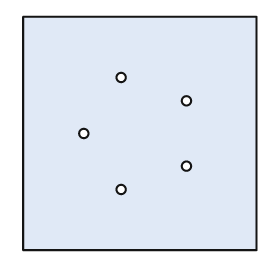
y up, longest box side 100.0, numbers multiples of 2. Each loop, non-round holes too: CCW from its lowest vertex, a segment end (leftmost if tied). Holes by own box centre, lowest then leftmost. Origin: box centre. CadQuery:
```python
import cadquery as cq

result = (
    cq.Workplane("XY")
    .moveTo(-50.0, -50.0)
    .lineTo(50.0, -50.0)
    .lineTo(50.0, 50.0)
    .lineTo(-50.0, 50.0)
    .close()
    .moveTo(-8.0, -24.0)
    .circle(2.0)
    .moveTo(20.0, -14.0)
    .circle(2.0)
    .moveTo(-24.0, 0.0)
    .circle(2.0)
    .moveTo(20.0, 14.0)
    .circle(2.0)
    .moveTo(-8.0, 24.0)
    .circle(2.0)
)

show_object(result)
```